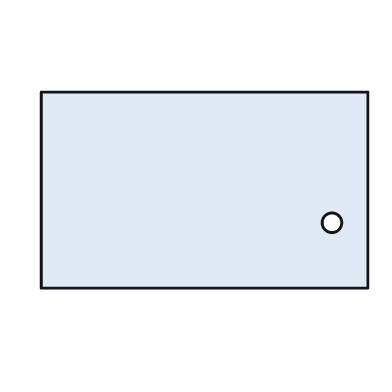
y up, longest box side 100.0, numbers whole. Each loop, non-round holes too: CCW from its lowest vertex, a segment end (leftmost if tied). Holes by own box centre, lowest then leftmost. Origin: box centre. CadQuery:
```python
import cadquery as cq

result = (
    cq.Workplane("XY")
    .moveTo(-50.0, -30.0)
    .lineTo(50.0, -30.0)
    .lineTo(50.0, 30.0)
    .lineTo(-50.0, 30.0)
    .close()
    .moveTo(39.0, -10.0)
    .circle(3.0)
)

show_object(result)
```